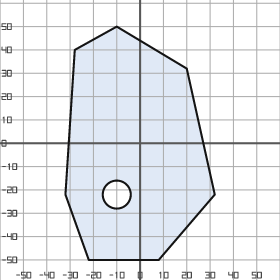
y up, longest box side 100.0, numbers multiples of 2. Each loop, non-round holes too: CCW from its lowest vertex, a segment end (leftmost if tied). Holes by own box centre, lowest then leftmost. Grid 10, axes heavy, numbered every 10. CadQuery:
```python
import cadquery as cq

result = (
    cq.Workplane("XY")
    .moveTo(-22.0, -50.0)
    .lineTo(8.0, -50.0)
    .lineTo(32.0, -22.0)
    .lineTo(20.0, 32.0)
    .lineTo(-10.0, 50.0)
    .lineTo(-28.0, 40.0)
    .lineTo(-32.0, -22.0)
    .close()
    .moveTo(-10.0, -22.0)
    .circle(6.0)
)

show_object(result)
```